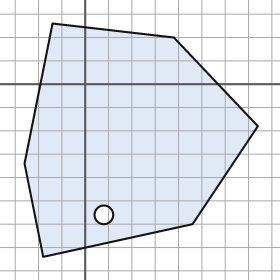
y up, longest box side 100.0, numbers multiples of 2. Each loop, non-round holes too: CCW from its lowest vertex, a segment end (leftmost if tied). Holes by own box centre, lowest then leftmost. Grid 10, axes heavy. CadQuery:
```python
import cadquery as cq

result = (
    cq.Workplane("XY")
    .moveTo(-18.0, -74.0)
    .lineTo(46.0, -60.0)
    .lineTo(74.0, -18.0)
    .lineTo(38.0, 20.0)
    .lineTo(-14.0, 26.0)
    .lineTo(-26.0, -34.0)
    .close()
    .moveTo(8.0, -56.0)
    .circle(4.0)
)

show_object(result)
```